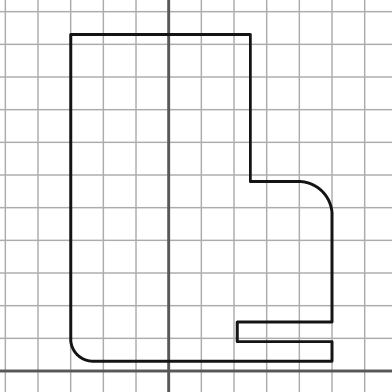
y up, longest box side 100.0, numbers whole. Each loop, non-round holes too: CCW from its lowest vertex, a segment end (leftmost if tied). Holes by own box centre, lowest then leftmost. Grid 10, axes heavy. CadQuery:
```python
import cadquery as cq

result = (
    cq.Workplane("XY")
    .moveTo(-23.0, 3.0)
    .lineTo(50.0, 3.0)
    .lineTo(50.0, 9.0)
    .lineTo(21.0, 9.0)
    .lineTo(21.0, 15.0)
    .lineTo(50.0, 15.0)
    .lineTo(50.0, 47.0)
    .threePointArc((47.0, 55.0), (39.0, 58.0))
    .lineTo(25.0, 58.0)
    .lineTo(25.0, 103.0)
    .lineTo(-30.0, 103.0)
    .lineTo(-30.0, 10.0)
    .threePointArc((-28.0, 5.0), (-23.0, 3.0))
    .close()
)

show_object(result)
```